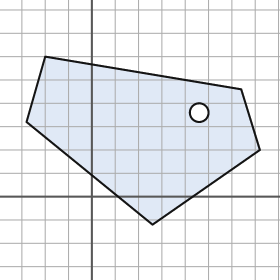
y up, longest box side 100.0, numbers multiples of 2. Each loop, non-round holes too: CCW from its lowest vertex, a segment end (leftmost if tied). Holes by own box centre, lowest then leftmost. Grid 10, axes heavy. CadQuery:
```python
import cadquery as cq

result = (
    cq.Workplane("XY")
    .moveTo(26.0, -12.0)
    .lineTo(72.0, 20.0)
    .lineTo(64.0, 46.0)
    .lineTo(-20.0, 60.0)
    .lineTo(-28.0, 32.0)
    .close()
    .moveTo(46.0, 36.0)
    .circle(4.0)
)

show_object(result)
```